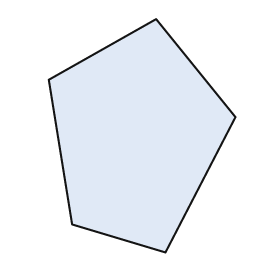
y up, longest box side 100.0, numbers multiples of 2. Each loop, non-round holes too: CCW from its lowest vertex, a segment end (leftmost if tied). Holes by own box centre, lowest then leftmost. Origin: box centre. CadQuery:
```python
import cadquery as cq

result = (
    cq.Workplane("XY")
    .moveTo(10.0, -50.0)
    .lineTo(40.0, 8.0)
    .lineTo(6.0, 50.0)
    .lineTo(-40.0, 24.0)
    .lineTo(-30.0, -38.0)
    .close()
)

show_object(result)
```